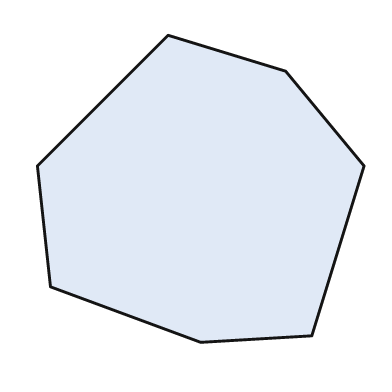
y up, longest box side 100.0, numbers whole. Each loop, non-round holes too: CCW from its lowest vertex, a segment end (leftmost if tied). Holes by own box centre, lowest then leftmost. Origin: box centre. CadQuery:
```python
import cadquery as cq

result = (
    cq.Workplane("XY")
    .moveTo(0.0, -47.0)
    .lineTo(34.0, -45.0)
    .lineTo(50.0, 7.0)
    .lineTo(26.0, 36.0)
    .lineTo(-10.0, 47.0)
    .lineTo(-50.0, 7.0)
    .lineTo(-46.0, -30.0)
    .close()
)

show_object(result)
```